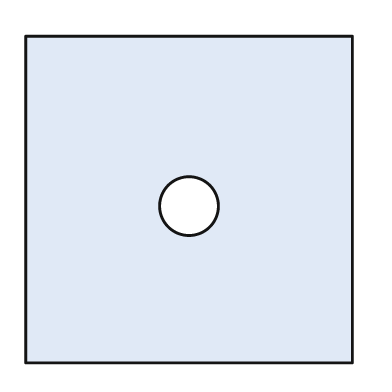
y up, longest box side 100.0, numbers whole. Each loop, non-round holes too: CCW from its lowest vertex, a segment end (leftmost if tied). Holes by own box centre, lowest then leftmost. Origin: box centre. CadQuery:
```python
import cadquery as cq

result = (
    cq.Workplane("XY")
    .moveTo(-50.0, -50.0)
    .lineTo(50.0, -50.0)
    .lineTo(50.0, 50.0)
    .lineTo(-50.0, 50.0)
    .close()
    .moveTo(0.0, -2.0)
    .circle(9.0)
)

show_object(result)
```